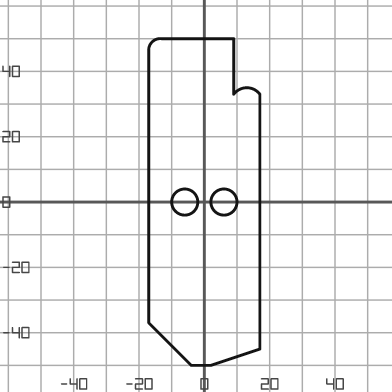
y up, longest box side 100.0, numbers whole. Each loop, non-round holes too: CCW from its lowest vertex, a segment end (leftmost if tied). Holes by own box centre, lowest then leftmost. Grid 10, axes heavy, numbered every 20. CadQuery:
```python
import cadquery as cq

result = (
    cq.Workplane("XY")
    .moveTo(-4.0, -50.0)
    .lineTo(2.0, -50.0)
    .lineTo(17.0, -45.0)
    .lineTo(17.0, 33.0)
    .threePointArc((13.0, 35.0), (9.0, 33.0))
    .lineTo(9.0, 50.0)
    .lineTo(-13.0, 50.0)
    .threePointArc((-16.0, 49.0), (-17.0, 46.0))
    .lineTo(-17.0, -37.0)
    .close()
    .moveTo(-6.0, 0.0)
    .circle(4.0)
    .moveTo(6.0, 0.0)
    .circle(4.0)
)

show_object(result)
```